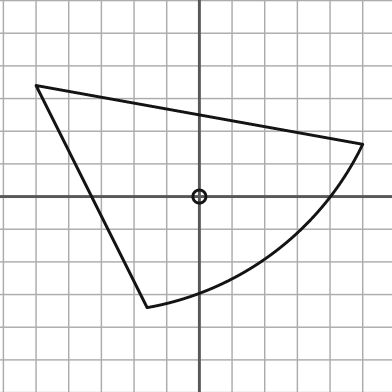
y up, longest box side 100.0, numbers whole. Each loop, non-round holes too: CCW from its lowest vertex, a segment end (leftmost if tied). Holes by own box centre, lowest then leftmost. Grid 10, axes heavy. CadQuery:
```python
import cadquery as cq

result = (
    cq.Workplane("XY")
    .moveTo(-16.0, -34.0)
    .threePointArc((23.0, -17.0), (50.0, 16.0))
    .lineTo(-50.0, 34.0)
    .close()
    .moveTo(0.0, 0.0)
    .circle(2.0)
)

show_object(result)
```